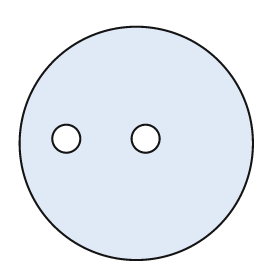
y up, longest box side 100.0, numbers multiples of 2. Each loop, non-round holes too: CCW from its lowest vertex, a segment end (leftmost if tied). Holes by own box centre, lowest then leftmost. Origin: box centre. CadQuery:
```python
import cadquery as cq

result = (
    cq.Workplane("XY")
    .moveTo(0.0, 0.0)
    .circle(50.0)
    .moveTo(-30.0, 2.0)
    .circle(6.0)
    .moveTo(4.0, 2.0)
    .circle(6.0)
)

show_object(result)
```